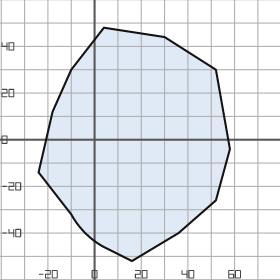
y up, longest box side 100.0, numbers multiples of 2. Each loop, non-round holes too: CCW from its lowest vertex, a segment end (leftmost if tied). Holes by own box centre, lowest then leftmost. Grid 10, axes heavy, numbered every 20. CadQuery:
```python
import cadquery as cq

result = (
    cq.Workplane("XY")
    .moveTo(16.0, -52.0)
    .lineTo(36.0, -40.0)
    .lineTo(52.0, -26.0)
    .lineTo(58.0, -4.0)
    .lineTo(52.0, 30.0)
    .lineTo(30.0, 44.0)
    .lineTo(4.0, 48.0)
    .lineTo(-10.0, 30.0)
    .lineTo(-18.0, 12.0)
    .lineTo(-24.0, -14.0)
    .lineTo(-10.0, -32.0)
    .threePointArc((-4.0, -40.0), (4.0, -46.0))
    .close()
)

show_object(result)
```